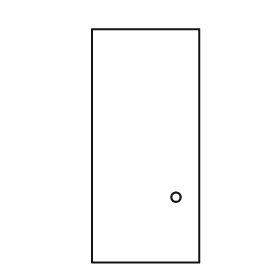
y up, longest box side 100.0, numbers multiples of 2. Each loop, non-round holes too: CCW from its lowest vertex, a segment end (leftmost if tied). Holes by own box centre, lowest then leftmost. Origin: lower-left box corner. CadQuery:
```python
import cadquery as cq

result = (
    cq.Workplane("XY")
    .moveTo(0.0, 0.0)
    .lineTo(46.0, 0.0)
    .lineTo(46.0, 100.0)
    .lineTo(0.0, 100.0)
    .close()
    .moveTo(36.0, 28.0)
    .circle(2.0)
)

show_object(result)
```